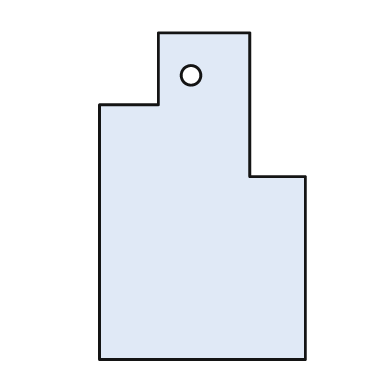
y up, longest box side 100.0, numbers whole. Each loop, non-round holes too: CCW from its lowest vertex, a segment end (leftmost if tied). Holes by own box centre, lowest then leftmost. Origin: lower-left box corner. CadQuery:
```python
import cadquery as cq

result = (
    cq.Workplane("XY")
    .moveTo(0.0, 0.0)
    .lineTo(63.0, 0.0)
    .lineTo(63.0, 56.0)
    .lineTo(46.0, 56.0)
    .lineTo(46.0, 100.0)
    .lineTo(18.0, 100.0)
    .lineTo(18.0, 78.0)
    .lineTo(0.0, 78.0)
    .close()
    .moveTo(28.0, 87.0)
    .circle(3.0)
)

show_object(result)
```